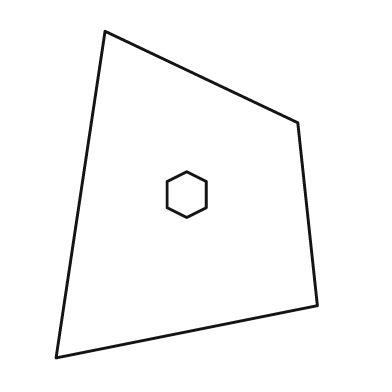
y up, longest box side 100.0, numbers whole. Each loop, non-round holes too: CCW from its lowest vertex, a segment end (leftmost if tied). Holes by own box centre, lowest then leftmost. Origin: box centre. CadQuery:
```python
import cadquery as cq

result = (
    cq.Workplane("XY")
    .moveTo(-40.0, -50.0)
    .lineTo(40.0, -34.0)
    .lineTo(34.0, 22.0)
    .lineTo(-25.0, 50.0)
    .close()
    .moveTo(0.0, -7.0)
    .lineTo(6.0, -4.0)
    .lineTo(6.0, 4.0)
    .lineTo(0.0, 7.0)
    .lineTo(-6.0, 4.0)
    .lineTo(-6.0, -4.0)
    .close()
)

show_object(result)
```